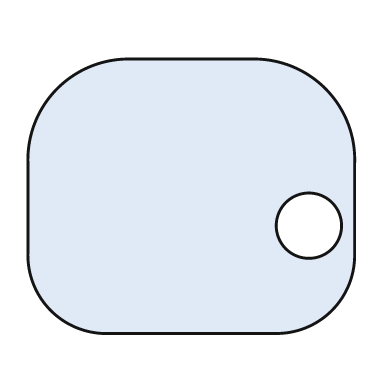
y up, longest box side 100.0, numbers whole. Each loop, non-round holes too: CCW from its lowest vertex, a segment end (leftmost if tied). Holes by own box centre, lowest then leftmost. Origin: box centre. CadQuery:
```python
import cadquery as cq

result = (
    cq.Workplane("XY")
    .moveTo(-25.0, -42.0)
    .lineTo(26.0, -42.0)
    .threePointArc((43.0, -35.0), (50.0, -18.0))
    .lineTo(50.0, 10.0)
    .threePointArc((41.0, 33.0), (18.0, 42.0))
    .lineTo(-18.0, 42.0)
    .threePointArc((-41.0, 33.0), (-50.0, 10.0))
    .lineTo(-50.0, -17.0)
    .threePointArc((-43.0, -35.0), (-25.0, -42.0))
    .close()
    .moveTo(36.0, -9.0)
    .circle(10.0)
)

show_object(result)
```